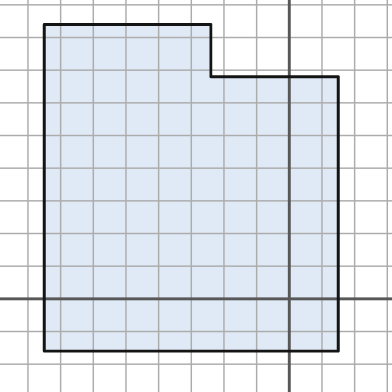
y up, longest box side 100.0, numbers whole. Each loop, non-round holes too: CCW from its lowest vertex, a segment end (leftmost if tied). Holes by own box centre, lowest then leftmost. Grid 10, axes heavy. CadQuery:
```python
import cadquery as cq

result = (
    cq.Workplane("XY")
    .moveTo(-75.0, -16.0)
    .lineTo(15.0, -16.0)
    .lineTo(15.0, 68.0)
    .lineTo(-24.0, 68.0)
    .lineTo(-24.0, 84.0)
    .lineTo(-75.0, 84.0)
    .close()
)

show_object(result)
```